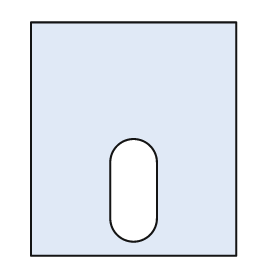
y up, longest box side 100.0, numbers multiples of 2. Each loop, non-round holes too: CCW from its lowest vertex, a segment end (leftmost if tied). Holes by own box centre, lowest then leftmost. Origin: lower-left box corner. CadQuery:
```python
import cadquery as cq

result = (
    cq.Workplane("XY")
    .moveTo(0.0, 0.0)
    .lineTo(88.0, 0.0)
    .lineTo(88.0, 100.0)
    .lineTo(0.0, 100.0)
    .close()
    .moveTo(34.0, 16.0)
    .threePointArc((44.0, 6.0), (54.0, 16.0))
    .lineTo(54.0, 40.0)
    .threePointArc((44.0, 50.0), (34.0, 40.0))
    .close()
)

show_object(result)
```